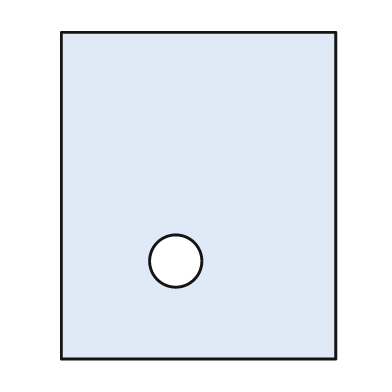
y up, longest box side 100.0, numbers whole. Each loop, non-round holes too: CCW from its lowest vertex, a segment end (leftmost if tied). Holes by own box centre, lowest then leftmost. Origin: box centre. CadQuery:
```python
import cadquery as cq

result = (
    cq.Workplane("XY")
    .moveTo(-42.0, -50.0)
    .lineTo(42.0, -50.0)
    .lineTo(42.0, 50.0)
    .lineTo(-42.0, 50.0)
    .close()
    .moveTo(-7.0, -20.0)
    .circle(8.0)
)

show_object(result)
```